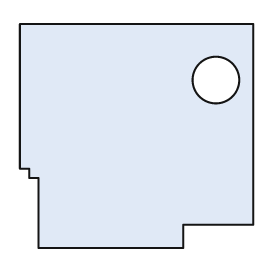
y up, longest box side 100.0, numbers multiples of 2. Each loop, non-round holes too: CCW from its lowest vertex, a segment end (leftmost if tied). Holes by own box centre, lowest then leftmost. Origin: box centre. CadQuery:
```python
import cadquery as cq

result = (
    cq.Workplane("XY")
    .moveTo(-42.0, -48.0)
    .lineTo(20.0, -48.0)
    .lineTo(20.0, -38.0)
    .lineTo(50.0, -38.0)
    .lineTo(50.0, 48.0)
    .lineTo(-50.0, 48.0)
    .lineTo(-50.0, -14.0)
    .lineTo(-46.0, -14.0)
    .lineTo(-46.0, -18.0)
    .lineTo(-42.0, -18.0)
    .close()
    .moveTo(34.0, 24.0)
    .circle(10.0)
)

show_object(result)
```